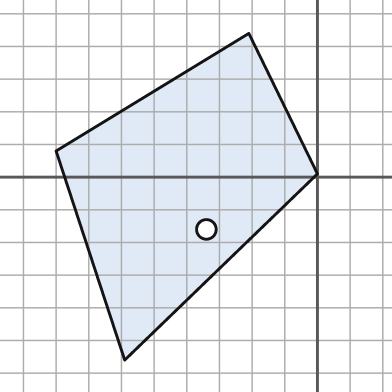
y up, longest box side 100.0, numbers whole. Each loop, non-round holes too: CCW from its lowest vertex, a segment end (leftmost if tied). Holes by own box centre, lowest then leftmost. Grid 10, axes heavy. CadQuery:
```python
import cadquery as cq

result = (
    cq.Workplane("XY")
    .moveTo(-59.0, -56.0)
    .lineTo(0.0, 1.0)
    .lineTo(-21.0, 44.0)
    .lineTo(-80.0, 8.0)
    .close()
    .moveTo(-34.0, -16.0)
    .circle(3.0)
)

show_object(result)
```